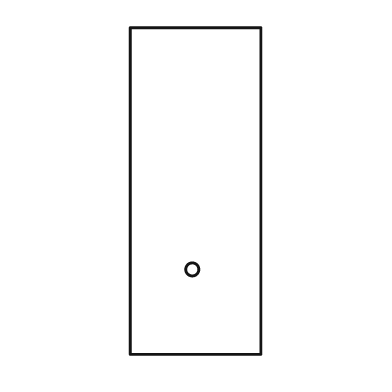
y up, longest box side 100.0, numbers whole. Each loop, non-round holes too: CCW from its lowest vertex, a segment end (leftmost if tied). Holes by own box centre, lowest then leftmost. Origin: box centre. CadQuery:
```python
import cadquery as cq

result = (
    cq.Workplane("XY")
    .moveTo(-20.0, -50.0)
    .lineTo(20.0, -50.0)
    .lineTo(20.0, 50.0)
    .lineTo(-20.0, 50.0)
    .close()
    .moveTo(-1.0, -24.0)
    .circle(2.0)
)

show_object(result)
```